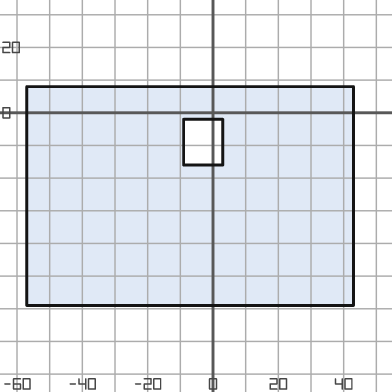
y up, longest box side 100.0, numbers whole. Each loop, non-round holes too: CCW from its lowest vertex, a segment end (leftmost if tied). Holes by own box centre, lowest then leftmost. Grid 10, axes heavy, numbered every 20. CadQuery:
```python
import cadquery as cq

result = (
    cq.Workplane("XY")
    .moveTo(-57.0, -59.0)
    .lineTo(43.0, -59.0)
    .lineTo(43.0, 8.0)
    .lineTo(-57.0, 8.0)
    .close()
    .moveTo(-9.0, -16.0)
    .lineTo(3.0, -16.0)
    .lineTo(3.0, -2.0)
    .lineTo(-9.0, -2.0)
    .close()
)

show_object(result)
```